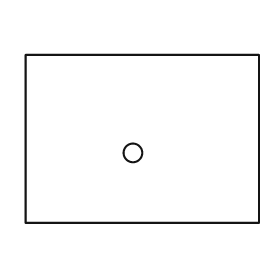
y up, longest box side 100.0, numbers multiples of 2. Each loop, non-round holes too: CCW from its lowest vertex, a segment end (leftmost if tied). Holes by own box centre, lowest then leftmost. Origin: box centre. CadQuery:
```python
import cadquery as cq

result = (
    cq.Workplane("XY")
    .moveTo(-50.0, -36.0)
    .lineTo(50.0, -36.0)
    .lineTo(50.0, 36.0)
    .lineTo(-50.0, 36.0)
    .close()
    .moveTo(-4.0, -6.0)
    .circle(4.0)
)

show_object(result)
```